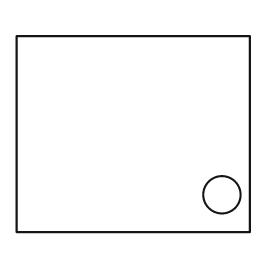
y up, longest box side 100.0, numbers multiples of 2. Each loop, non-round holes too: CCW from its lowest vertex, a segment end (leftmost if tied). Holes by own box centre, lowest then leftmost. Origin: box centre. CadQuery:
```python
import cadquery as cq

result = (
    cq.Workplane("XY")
    .moveTo(-50.0, -42.0)
    .lineTo(50.0, -42.0)
    .lineTo(50.0, 42.0)
    .lineTo(-50.0, 42.0)
    .close()
    .moveTo(38.0, -26.0)
    .circle(8.0)
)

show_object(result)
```